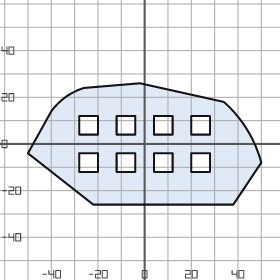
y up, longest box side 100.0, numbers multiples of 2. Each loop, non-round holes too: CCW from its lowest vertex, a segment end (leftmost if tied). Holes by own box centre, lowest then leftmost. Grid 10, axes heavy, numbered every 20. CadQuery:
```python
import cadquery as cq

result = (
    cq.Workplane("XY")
    .moveTo(-22.0, -26.0)
    .lineTo(38.0, -26.0)
    .lineTo(50.0, -8.0)
    .threePointArc((44.0, 6.0), (34.0, 18.0))
    .lineTo(-2.0, 26.0)
    .lineTo(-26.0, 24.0)
    .threePointArc((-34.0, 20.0), (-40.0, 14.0))
    .lineTo(-50.0, -4.0)
    .close()
    .moveTo(-28.0, -12.0)
    .lineTo(-20.0, -12.0)
    .lineTo(-20.0, -4.0)
    .lineTo(-28.0, -4.0)
    .close()
    .moveTo(-12.0, -12.0)
    .lineTo(-4.0, -12.0)
    .lineTo(-4.0, -4.0)
    .lineTo(-12.0, -4.0)
    .close()
    .moveTo(4.0, -12.0)
    .lineTo(12.0, -12.0)
    .lineTo(12.0, -4.0)
    .lineTo(4.0, -4.0)
    .close()
    .moveTo(20.0, -12.0)
    .lineTo(28.0, -12.0)
    .lineTo(28.0, -4.0)
    .lineTo(20.0, -4.0)
    .close()
    .moveTo(-28.0, 4.0)
    .lineTo(-20.0, 4.0)
    .lineTo(-20.0, 12.0)
    .lineTo(-28.0, 12.0)
    .close()
    .moveTo(-12.0, 4.0)
    .lineTo(-4.0, 4.0)
    .lineTo(-4.0, 12.0)
    .lineTo(-12.0, 12.0)
    .close()
    .moveTo(4.0, 4.0)
    .lineTo(12.0, 4.0)
    .lineTo(12.0, 12.0)
    .lineTo(4.0, 12.0)
    .close()
    .moveTo(20.0, 4.0)
    .lineTo(28.0, 4.0)
    .lineTo(28.0, 12.0)
    .lineTo(20.0, 12.0)
    .close()
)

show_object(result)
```